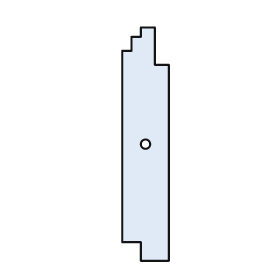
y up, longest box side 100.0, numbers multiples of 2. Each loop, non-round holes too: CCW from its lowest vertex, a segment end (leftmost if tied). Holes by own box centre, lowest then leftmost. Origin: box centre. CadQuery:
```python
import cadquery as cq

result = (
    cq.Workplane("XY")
    .moveTo(-2.0, -50.0)
    .lineTo(10.0, -50.0)
    .lineTo(10.0, 34.0)
    .lineTo(4.0, 34.0)
    .lineTo(4.0, 50.0)
    .lineTo(-2.0, 50.0)
    .lineTo(-2.0, 46.0)
    .lineTo(-6.0, 46.0)
    .lineTo(-6.0, 40.0)
    .lineTo(-10.0, 40.0)
    .lineTo(-10.0, -42.0)
    .lineTo(-2.0, -42.0)
    .close()
    .moveTo(0.0, 0.0)
    .circle(2.0)
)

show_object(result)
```